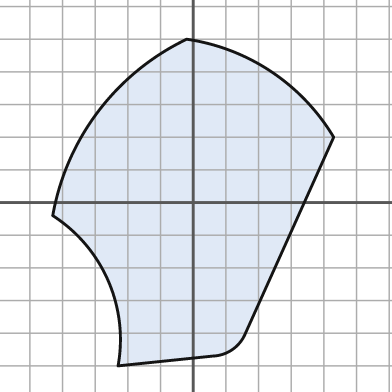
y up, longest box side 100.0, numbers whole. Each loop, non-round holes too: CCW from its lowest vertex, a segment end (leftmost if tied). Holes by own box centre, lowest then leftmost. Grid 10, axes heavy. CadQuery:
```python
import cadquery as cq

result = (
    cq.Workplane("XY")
    .moveTo(-23.0, -50.0)
    .lineTo(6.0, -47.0)
    .threePointArc((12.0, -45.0), (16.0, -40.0))
    .lineTo(43.0, 20.0)
    .threePointArc((24.0, 40.0), (-2.0, 50.0))
    .threePointArc((-29.0, 28.0), (-43.0, -4.0))
    .threePointArc((-26.0, -24.0), (-23.0, -50.0))
    .close()
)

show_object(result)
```